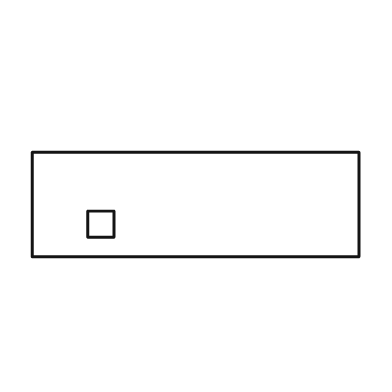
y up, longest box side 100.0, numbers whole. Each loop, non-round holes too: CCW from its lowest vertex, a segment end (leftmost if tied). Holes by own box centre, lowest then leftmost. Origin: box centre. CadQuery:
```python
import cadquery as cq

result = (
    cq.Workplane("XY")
    .moveTo(-50.0, -16.0)
    .lineTo(50.0, -16.0)
    .lineTo(50.0, 16.0)
    .lineTo(-50.0, 16.0)
    .close()
    .moveTo(-33.0, -10.0)
    .lineTo(-25.0, -10.0)
    .lineTo(-25.0, -2.0)
    .lineTo(-33.0, -2.0)
    .close()
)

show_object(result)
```